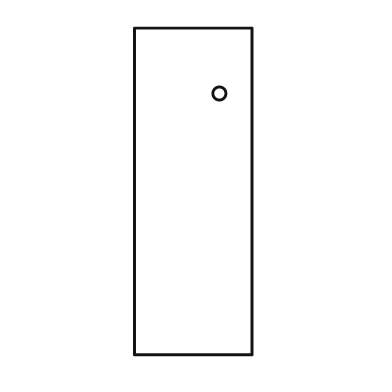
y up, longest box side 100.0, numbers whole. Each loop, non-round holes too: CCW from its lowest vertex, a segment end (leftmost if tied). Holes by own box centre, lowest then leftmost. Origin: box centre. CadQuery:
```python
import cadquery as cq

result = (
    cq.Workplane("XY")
    .moveTo(-18.0, -50.0)
    .lineTo(18.0, -50.0)
    .lineTo(18.0, 50.0)
    .lineTo(-18.0, 50.0)
    .close()
    .moveTo(8.0, 30.0)
    .circle(2.0)
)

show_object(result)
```